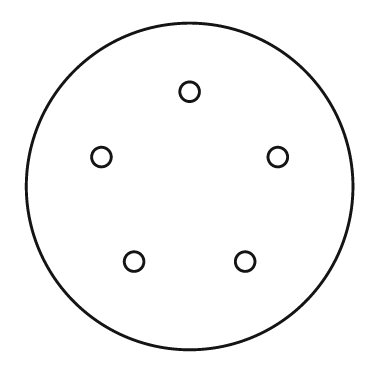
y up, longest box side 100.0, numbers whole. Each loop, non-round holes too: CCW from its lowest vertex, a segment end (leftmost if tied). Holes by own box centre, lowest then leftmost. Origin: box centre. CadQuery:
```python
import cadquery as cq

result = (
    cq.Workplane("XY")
    .moveTo(0.0, 0.0)
    .circle(50.0)
    .moveTo(-17.0, -23.0)
    .circle(3.0)
    .moveTo(17.0, -23.0)
    .circle(3.0)
    .moveTo(-27.0, 9.0)
    .circle(3.0)
    .moveTo(27.0, 9.0)
    .circle(3.0)
    .moveTo(0.0, 29.0)
    .circle(3.0)
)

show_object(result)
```